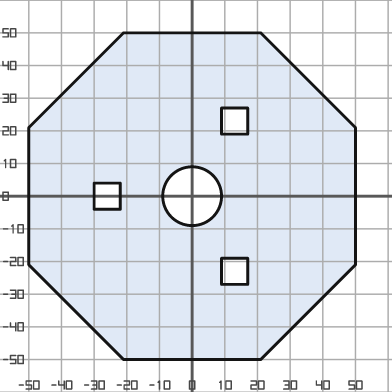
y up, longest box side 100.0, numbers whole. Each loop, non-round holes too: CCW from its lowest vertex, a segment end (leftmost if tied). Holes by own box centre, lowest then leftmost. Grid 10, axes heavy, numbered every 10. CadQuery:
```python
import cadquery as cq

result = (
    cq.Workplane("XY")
    .moveTo(-21.0, -50.0)
    .lineTo(21.0, -50.0)
    .lineTo(50.0, -21.0)
    .lineTo(50.0, 21.0)
    .lineTo(21.0, 50.0)
    .lineTo(-21.0, 50.0)
    .lineTo(-50.0, 21.0)
    .lineTo(-50.0, -21.0)
    .close()
    .moveTo(9.0, -27.0)
    .lineTo(17.0, -27.0)
    .lineTo(17.0, -19.0)
    .lineTo(9.0, -19.0)
    .close()
    .moveTo(-30.0, -4.0)
    .lineTo(-22.0, -4.0)
    .lineTo(-22.0, 4.0)
    .lineTo(-30.0, 4.0)
    .close()
    .moveTo(0.0, 0.0)
    .circle(9.0)
    .moveTo(9.0, 19.0)
    .lineTo(17.0, 19.0)
    .lineTo(17.0, 27.0)
    .lineTo(9.0, 27.0)
    .close()
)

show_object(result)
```